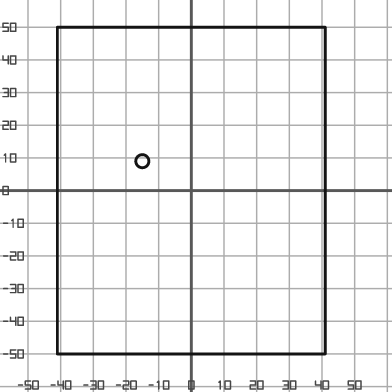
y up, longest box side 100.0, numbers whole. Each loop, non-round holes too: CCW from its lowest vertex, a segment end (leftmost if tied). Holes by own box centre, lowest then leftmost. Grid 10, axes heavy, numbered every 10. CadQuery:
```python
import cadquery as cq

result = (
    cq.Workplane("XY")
    .moveTo(-41.0, -50.0)
    .lineTo(41.0, -50.0)
    .lineTo(41.0, 50.0)
    .lineTo(-41.0, 50.0)
    .close()
    .moveTo(-15.0, 9.0)
    .circle(2.0)
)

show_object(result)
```